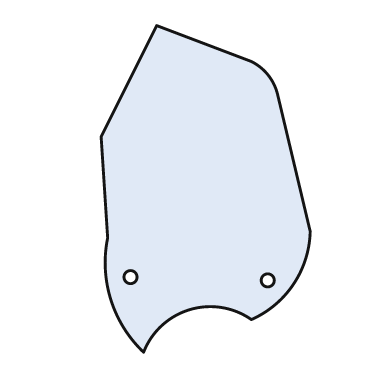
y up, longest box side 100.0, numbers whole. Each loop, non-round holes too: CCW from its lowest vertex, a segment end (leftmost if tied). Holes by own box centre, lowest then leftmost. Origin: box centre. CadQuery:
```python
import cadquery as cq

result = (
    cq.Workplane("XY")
    .moveTo(-19.0, -50.0)
    .threePointArc((-5.0, -37.0), (14.0, -40.0))
    .threePointArc((27.0, -29.0), (32.0, -13.0))
    .lineTo(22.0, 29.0)
    .threePointArc((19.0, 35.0), (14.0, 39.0))
    .lineTo(-15.0, 50.0)
    .lineTo(-32.0, 16.0)
    .lineTo(-30.0, -15.0)
    .threePointArc((-29.0, -34.0), (-19.0, -50.0))
    .close()
    .moveTo(19.0, -28.0)
    .circle(2.0)
    .moveTo(-23.0, -27.0)
    .circle(2.0)
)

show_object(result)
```